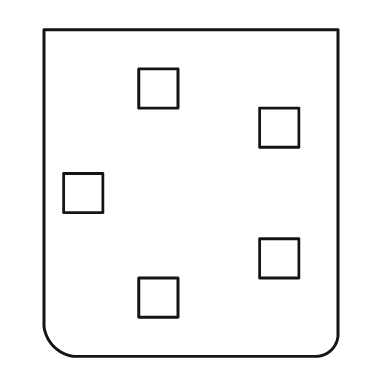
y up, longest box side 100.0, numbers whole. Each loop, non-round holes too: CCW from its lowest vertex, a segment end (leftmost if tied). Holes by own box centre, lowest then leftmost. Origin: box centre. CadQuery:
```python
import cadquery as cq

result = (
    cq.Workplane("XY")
    .moveTo(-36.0, -50.0)
    .lineTo(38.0, -50.0)
    .threePointArc((43.0, -48.0), (45.0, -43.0))
    .lineTo(45.0, 50.0)
    .lineTo(-45.0, 50.0)
    .lineTo(-45.0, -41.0)
    .threePointArc((-42.0, -47.0), (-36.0, -50.0))
    .close()
    .moveTo(-16.0, -38.0)
    .lineTo(-4.0, -38.0)
    .lineTo(-4.0, -26.0)
    .lineTo(-16.0, -26.0)
    .close()
    .moveTo(21.0, -26.0)
    .lineTo(33.0, -26.0)
    .lineTo(33.0, -14.0)
    .lineTo(21.0, -14.0)
    .close()
    .moveTo(-39.0, -6.0)
    .lineTo(-27.0, -6.0)
    .lineTo(-27.0, 6.0)
    .lineTo(-39.0, 6.0)
    .close()
    .moveTo(21.0, 14.0)
    .lineTo(33.0, 14.0)
    .lineTo(33.0, 26.0)
    .lineTo(21.0, 26.0)
    .close()
    .moveTo(-16.0, 26.0)
    .lineTo(-4.0, 26.0)
    .lineTo(-4.0, 38.0)
    .lineTo(-16.0, 38.0)
    .close()
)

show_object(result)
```